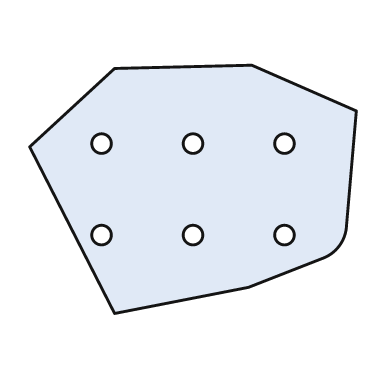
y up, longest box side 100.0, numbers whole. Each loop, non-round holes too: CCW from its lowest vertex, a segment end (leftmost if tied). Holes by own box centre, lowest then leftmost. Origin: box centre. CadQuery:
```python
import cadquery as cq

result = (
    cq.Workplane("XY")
    .moveTo(-24.0, -38.0)
    .lineTo(17.0, -30.0)
    .lineTo(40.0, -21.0)
    .threePointArc((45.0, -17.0), (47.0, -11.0))
    .lineTo(50.0, 24.0)
    .lineTo(18.0, 38.0)
    .lineTo(-24.0, 37.0)
    .lineTo(-50.0, 13.0)
    .close()
    .moveTo(-28.0, -14.0)
    .circle(3.0)
    .moveTo(0.0, -14.0)
    .circle(3.0)
    .moveTo(28.0, -14.0)
    .circle(3.0)
    .moveTo(-28.0, 14.0)
    .circle(3.0)
    .moveTo(0.0, 14.0)
    .circle(3.0)
    .moveTo(28.0, 14.0)
    .circle(3.0)
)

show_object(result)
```